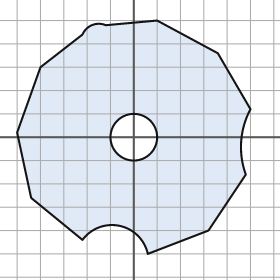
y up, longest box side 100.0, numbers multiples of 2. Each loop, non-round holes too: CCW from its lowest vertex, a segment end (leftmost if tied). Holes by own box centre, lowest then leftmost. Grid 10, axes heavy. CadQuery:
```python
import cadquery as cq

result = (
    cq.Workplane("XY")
    .moveTo(6.0, -50.0)
    .lineTo(32.0, -40.0)
    .lineTo(48.0, -16.0)
    .threePointArc((46.0, -2.0), (50.0, 12.0))
    .lineTo(36.0, 36.0)
    .lineTo(10.0, 50.0)
    .lineTo(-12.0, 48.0)
    .threePointArc((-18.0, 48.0), (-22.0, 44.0))
    .lineTo(-40.0, 30.0)
    .lineTo(-50.0, 2.0)
    .lineTo(-44.0, -26.0)
    .lineTo(-22.0, -44.0)
    .threePointArc((-6.0, -38.0), (6.0, -50.0))
    .close()
    .moveTo(0.0, 0.0)
    .circle(10.0)
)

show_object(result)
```